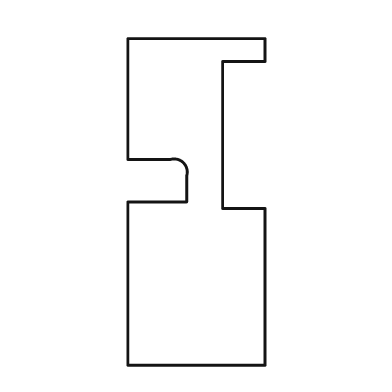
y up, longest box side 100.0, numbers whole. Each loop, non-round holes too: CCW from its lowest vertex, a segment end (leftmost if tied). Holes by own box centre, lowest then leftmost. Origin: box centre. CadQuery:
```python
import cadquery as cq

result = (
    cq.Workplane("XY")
    .moveTo(-21.0, -50.0)
    .lineTo(21.0, -50.0)
    .lineTo(21.0, -2.0)
    .lineTo(8.0, -2.0)
    .lineTo(8.0, 43.0)
    .lineTo(21.0, 43.0)
    .lineTo(21.0, 50.0)
    .lineTo(-21.0, 50.0)
    .lineTo(-21.0, 13.0)
    .lineTo(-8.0, 13.0)
    .threePointArc((-4.0, 12.0), (-3.0, 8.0))
    .lineTo(-3.0, 0.0)
    .lineTo(-21.0, 0.0)
    .close()
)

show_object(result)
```